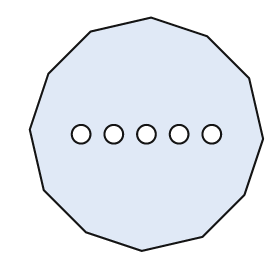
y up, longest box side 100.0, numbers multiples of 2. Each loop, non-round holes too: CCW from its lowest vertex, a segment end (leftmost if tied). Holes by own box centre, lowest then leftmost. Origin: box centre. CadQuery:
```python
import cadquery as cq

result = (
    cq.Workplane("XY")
    .moveTo(-2.0, -50.0)
    .lineTo(24.0, -44.0)
    .lineTo(42.0, -26.0)
    .lineTo(50.0, -2.0)
    .lineTo(44.0, 24.0)
    .lineTo(26.0, 42.0)
    .lineTo(2.0, 50.0)
    .lineTo(-24.0, 44.0)
    .lineTo(-42.0, 26.0)
    .lineTo(-50.0, 2.0)
    .lineTo(-44.0, -24.0)
    .lineTo(-26.0, -42.0)
    .close()
    .moveTo(-28.0, 0.0)
    .circle(4.0)
    .moveTo(-14.0, 0.0)
    .circle(4.0)
    .moveTo(0.0, 0.0)
    .circle(4.0)
    .moveTo(14.0, 0.0)
    .circle(4.0)
    .moveTo(28.0, 0.0)
    .circle(4.0)
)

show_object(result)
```